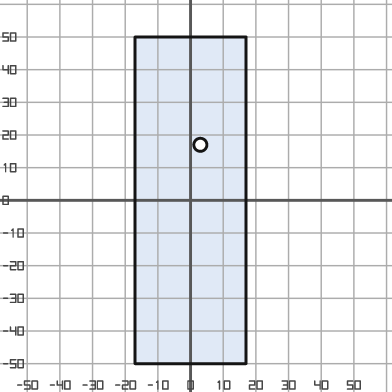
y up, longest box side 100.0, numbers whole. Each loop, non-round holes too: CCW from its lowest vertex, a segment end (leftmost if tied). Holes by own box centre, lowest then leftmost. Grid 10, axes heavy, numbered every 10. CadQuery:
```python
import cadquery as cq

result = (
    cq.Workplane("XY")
    .moveTo(-17.0, -50.0)
    .lineTo(17.0, -50.0)
    .lineTo(17.0, 50.0)
    .lineTo(-17.0, 50.0)
    .close()
    .moveTo(3.0, 17.0)
    .circle(2.0)
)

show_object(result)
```